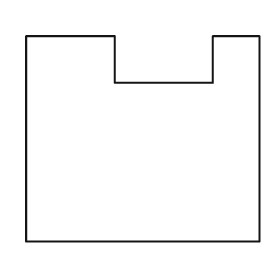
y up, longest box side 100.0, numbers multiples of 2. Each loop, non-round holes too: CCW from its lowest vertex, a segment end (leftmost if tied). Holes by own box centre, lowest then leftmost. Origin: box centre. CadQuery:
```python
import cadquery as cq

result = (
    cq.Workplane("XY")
    .moveTo(-50.0, -44.0)
    .lineTo(50.0, -44.0)
    .lineTo(50.0, 44.0)
    .lineTo(30.0, 44.0)
    .lineTo(30.0, 24.0)
    .lineTo(-12.0, 24.0)
    .lineTo(-12.0, 44.0)
    .lineTo(-50.0, 44.0)
    .close()
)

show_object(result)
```